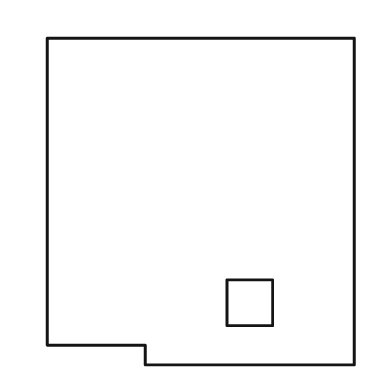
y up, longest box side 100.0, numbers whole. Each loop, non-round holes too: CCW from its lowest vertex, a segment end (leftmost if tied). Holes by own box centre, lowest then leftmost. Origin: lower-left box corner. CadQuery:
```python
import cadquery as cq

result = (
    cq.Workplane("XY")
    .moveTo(30.0, 0.0)
    .lineTo(94.0, 0.0)
    .lineTo(94.0, 100.0)
    .lineTo(0.0, 100.0)
    .lineTo(0.0, 6.0)
    .lineTo(30.0, 6.0)
    .close()
    .moveTo(55.0, 12.0)
    .lineTo(69.0, 12.0)
    .lineTo(69.0, 26.0)
    .lineTo(55.0, 26.0)
    .close()
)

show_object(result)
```